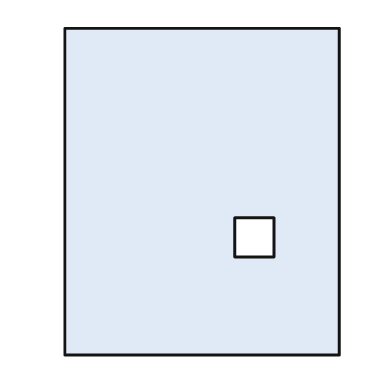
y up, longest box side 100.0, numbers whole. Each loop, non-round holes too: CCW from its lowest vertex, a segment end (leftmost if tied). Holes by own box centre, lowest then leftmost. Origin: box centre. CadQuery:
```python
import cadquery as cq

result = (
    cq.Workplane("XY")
    .moveTo(-42.0, -50.0)
    .lineTo(42.0, -50.0)
    .lineTo(42.0, 50.0)
    .lineTo(-42.0, 50.0)
    .close()
    .moveTo(10.0, -20.0)
    .lineTo(22.0, -20.0)
    .lineTo(22.0, -8.0)
    .lineTo(10.0, -8.0)
    .close()
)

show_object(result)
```